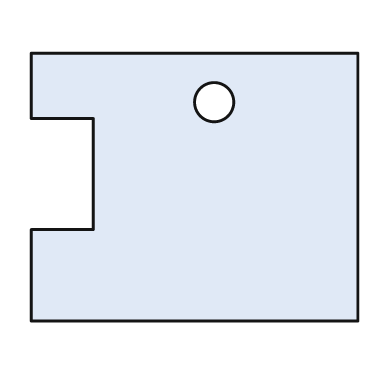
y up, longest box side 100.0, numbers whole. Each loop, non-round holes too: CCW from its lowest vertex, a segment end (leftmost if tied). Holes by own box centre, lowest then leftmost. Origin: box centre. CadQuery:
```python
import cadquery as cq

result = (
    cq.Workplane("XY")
    .moveTo(-50.0, -41.0)
    .lineTo(50.0, -41.0)
    .lineTo(50.0, 41.0)
    .lineTo(-50.0, 41.0)
    .lineTo(-50.0, 21.0)
    .lineTo(-31.0, 21.0)
    .lineTo(-31.0, -13.0)
    .lineTo(-50.0, -13.0)
    .close()
    .moveTo(6.0, 26.0)
    .circle(6.0)
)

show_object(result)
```